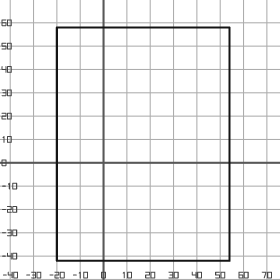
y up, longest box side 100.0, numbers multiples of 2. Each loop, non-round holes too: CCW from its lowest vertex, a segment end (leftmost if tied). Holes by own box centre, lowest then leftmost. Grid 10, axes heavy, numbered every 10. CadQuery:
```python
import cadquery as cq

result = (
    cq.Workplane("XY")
    .moveTo(-20.0, -42.0)
    .lineTo(54.0, -42.0)
    .lineTo(54.0, 58.0)
    .lineTo(-20.0, 58.0)
    .close()
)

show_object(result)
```